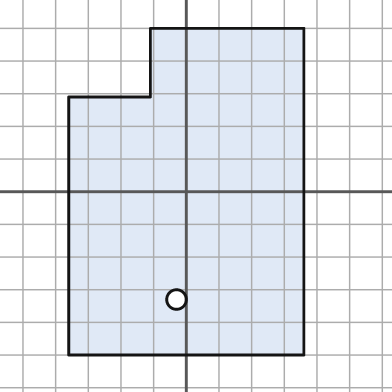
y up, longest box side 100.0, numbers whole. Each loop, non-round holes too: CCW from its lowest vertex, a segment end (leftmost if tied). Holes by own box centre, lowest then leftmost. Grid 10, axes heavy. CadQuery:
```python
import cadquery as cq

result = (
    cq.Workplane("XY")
    .moveTo(-36.0, -50.0)
    .lineTo(36.0, -50.0)
    .lineTo(36.0, 50.0)
    .lineTo(-11.0, 50.0)
    .lineTo(-11.0, 29.0)
    .lineTo(-36.0, 29.0)
    .close()
    .moveTo(-3.0, -33.0)
    .circle(3.0)
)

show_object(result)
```